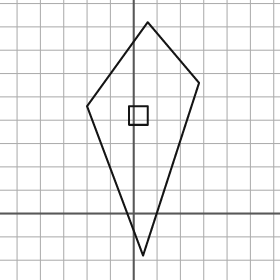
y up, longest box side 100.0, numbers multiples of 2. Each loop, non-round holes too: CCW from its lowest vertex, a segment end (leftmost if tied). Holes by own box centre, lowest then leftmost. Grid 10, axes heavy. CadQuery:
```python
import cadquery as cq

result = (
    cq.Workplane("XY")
    .moveTo(4.0, -18.0)
    .lineTo(28.0, 56.0)
    .lineTo(6.0, 82.0)
    .lineTo(-20.0, 46.0)
    .close()
    .moveTo(-2.0, 38.0)
    .lineTo(6.0, 38.0)
    .lineTo(6.0, 46.0)
    .lineTo(-2.0, 46.0)
    .close()
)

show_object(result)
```